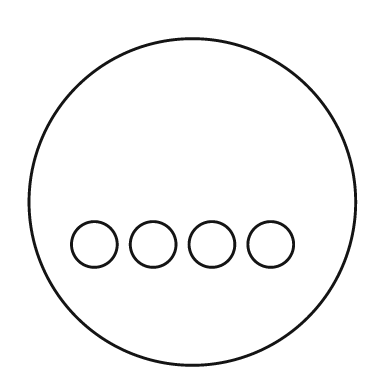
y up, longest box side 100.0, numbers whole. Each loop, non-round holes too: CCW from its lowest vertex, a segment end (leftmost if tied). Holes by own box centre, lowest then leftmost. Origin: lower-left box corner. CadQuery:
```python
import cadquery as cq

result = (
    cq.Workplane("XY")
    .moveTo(50.0, 50.0)
    .circle(50.0)
    .moveTo(20.0, 37.0)
    .circle(7.0)
    .moveTo(38.0, 37.0)
    .circle(7.0)
    .moveTo(56.0, 37.0)
    .circle(7.0)
    .moveTo(74.0, 37.0)
    .circle(7.0)
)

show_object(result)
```